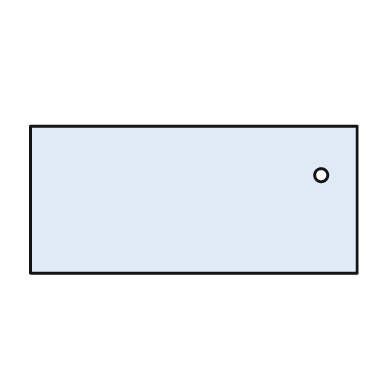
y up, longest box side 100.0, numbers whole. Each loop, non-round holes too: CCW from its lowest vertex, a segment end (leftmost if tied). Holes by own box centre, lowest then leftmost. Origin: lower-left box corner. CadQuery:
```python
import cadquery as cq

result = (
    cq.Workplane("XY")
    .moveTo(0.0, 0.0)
    .lineTo(100.0, 0.0)
    .lineTo(100.0, 45.0)
    .lineTo(0.0, 45.0)
    .close()
    .moveTo(89.0, 30.0)
    .circle(2.0)
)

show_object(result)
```